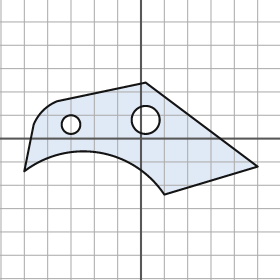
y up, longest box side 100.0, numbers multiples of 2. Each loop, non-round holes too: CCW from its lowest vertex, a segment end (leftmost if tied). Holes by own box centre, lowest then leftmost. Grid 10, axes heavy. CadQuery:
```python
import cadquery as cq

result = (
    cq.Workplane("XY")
    .moveTo(10.0, -24.0)
    .lineTo(50.0, -12.0)
    .lineTo(2.0, 24.0)
    .lineTo(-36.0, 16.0)
    .threePointArc((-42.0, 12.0), (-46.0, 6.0))
    .lineTo(-50.0, -14.0)
    .threePointArc((-18.0, -6.0), (10.0, -24.0))
    .close()
    .moveTo(-30.0, 6.0)
    .circle(4.0)
    .moveTo(2.0, 8.0)
    .circle(6.0)
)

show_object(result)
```